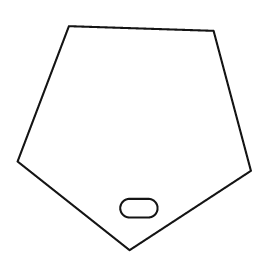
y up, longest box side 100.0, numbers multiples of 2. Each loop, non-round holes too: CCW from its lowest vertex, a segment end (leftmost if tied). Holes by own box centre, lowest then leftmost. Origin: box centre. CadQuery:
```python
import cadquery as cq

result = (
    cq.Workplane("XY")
    .moveTo(-2.0, -48.0)
    .lineTo(50.0, -14.0)
    .lineTo(34.0, 46.0)
    .lineTo(-28.0, 48.0)
    .lineTo(-50.0, -10.0)
    .close()
    .moveTo(-2.0, -34.0)
    .lineTo(6.0, -34.0)
    .threePointArc((10.0, -30.0), (6.0, -26.0))
    .lineTo(-2.0, -26.0)
    .threePointArc((-6.0, -30.0), (-2.0, -34.0))
    .close()
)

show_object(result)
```